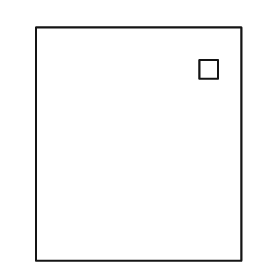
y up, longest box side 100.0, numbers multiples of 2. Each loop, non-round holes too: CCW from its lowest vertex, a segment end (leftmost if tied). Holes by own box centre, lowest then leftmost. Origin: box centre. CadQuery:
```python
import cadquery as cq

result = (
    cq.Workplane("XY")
    .moveTo(-44.0, -50.0)
    .lineTo(44.0, -50.0)
    .lineTo(44.0, 50.0)
    .lineTo(-44.0, 50.0)
    .close()
    .moveTo(26.0, 28.0)
    .lineTo(34.0, 28.0)
    .lineTo(34.0, 36.0)
    .lineTo(26.0, 36.0)
    .close()
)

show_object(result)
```